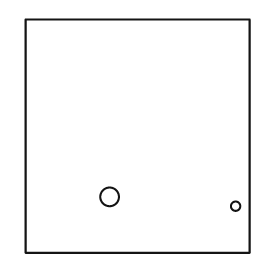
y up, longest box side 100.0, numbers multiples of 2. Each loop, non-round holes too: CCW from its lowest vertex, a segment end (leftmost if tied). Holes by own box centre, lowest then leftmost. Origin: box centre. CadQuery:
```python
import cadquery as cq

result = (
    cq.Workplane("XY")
    .moveTo(-48.0, -50.0)
    .lineTo(48.0, -50.0)
    .lineTo(48.0, 50.0)
    .lineTo(-48.0, 50.0)
    .close()
    .moveTo(42.0, -30.0)
    .circle(2.0)
    .moveTo(-12.0, -26.0)
    .circle(4.0)
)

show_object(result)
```